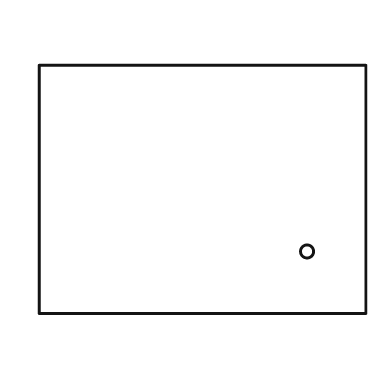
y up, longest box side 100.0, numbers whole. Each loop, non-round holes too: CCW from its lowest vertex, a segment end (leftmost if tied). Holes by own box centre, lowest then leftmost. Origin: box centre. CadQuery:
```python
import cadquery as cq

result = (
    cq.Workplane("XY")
    .moveTo(-50.0, -38.0)
    .lineTo(50.0, -38.0)
    .lineTo(50.0, 38.0)
    .lineTo(-50.0, 38.0)
    .close()
    .moveTo(32.0, -19.0)
    .circle(2.0)
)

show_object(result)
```